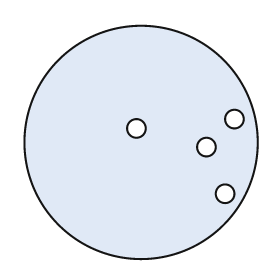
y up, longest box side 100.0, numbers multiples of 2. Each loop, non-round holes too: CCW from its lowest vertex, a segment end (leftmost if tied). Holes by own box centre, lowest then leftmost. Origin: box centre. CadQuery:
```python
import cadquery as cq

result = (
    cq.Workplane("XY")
    .moveTo(0.0, 0.0)
    .circle(50.0)
    .moveTo(36.0, -22.0)
    .circle(4.0)
    .moveTo(28.0, -2.0)
    .circle(4.0)
    .moveTo(-2.0, 6.0)
    .circle(4.0)
    .moveTo(40.0, 10.0)
    .circle(4.0)
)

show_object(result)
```